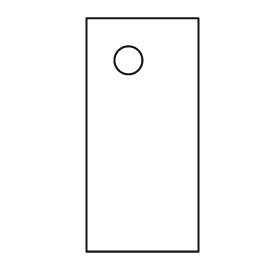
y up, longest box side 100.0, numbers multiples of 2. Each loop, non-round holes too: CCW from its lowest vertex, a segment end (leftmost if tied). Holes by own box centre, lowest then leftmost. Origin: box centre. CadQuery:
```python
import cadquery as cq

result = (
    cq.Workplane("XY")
    .moveTo(-24.0, -50.0)
    .lineTo(24.0, -50.0)
    .lineTo(24.0, 50.0)
    .lineTo(-24.0, 50.0)
    .close()
    .moveTo(-6.0, 32.0)
    .circle(6.0)
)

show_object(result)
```